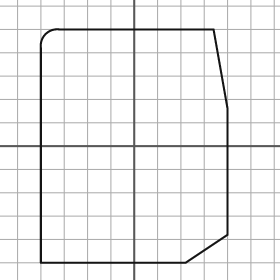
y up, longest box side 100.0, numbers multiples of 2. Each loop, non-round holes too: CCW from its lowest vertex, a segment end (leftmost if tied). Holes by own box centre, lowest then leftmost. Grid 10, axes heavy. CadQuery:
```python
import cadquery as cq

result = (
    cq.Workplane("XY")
    .moveTo(-40.0, -50.0)
    .lineTo(22.0, -50.0)
    .lineTo(40.0, -38.0)
    .lineTo(40.0, 16.0)
    .lineTo(34.0, 50.0)
    .lineTo(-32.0, 50.0)
    .threePointArc((-38.0, 48.0), (-40.0, 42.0))
    .close()
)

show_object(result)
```